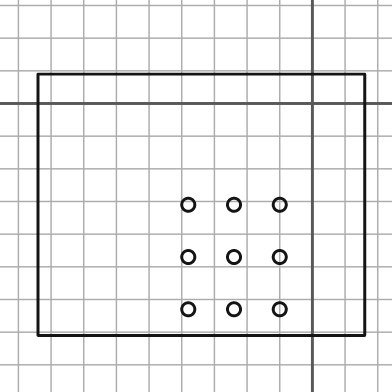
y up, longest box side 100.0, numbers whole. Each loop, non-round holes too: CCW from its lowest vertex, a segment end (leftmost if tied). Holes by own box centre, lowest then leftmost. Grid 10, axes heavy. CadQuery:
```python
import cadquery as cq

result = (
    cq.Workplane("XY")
    .moveTo(-84.0, -71.0)
    .lineTo(16.0, -71.0)
    .lineTo(16.0, 9.0)
    .lineTo(-84.0, 9.0)
    .close()
    .moveTo(-38.0, -63.0)
    .circle(2.0)
    .moveTo(-24.0, -63.0)
    .circle(2.0)
    .moveTo(-10.0, -63.0)
    .circle(2.0)
    .moveTo(-38.0, -47.0)
    .circle(2.0)
    .moveTo(-24.0, -47.0)
    .circle(2.0)
    .moveTo(-10.0, -47.0)
    .circle(2.0)
    .moveTo(-38.0, -31.0)
    .circle(2.0)
    .moveTo(-24.0, -31.0)
    .circle(2.0)
    .moveTo(-10.0, -31.0)
    .circle(2.0)
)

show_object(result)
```